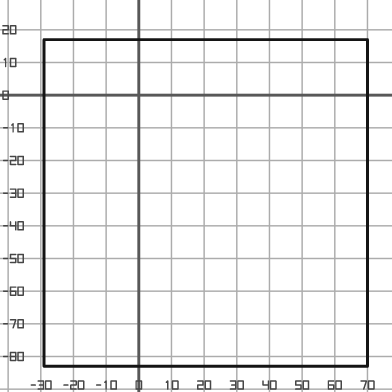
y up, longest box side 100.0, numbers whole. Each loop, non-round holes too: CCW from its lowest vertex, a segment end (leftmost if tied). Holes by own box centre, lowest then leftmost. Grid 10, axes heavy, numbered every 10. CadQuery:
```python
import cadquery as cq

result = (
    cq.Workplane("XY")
    .moveTo(-29.0, -83.0)
    .lineTo(70.0, -83.0)
    .lineTo(70.0, 17.0)
    .lineTo(-29.0, 17.0)
    .close()
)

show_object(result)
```